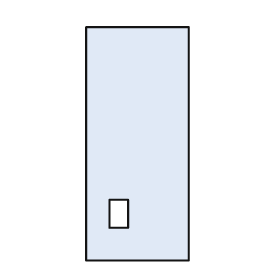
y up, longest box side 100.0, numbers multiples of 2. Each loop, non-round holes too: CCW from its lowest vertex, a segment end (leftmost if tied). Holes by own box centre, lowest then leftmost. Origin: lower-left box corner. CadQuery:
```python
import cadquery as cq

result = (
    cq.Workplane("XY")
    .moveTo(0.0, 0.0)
    .lineTo(44.0, 0.0)
    .lineTo(44.0, 100.0)
    .lineTo(0.0, 100.0)
    .close()
    .moveTo(10.0, 14.0)
    .lineTo(18.0, 14.0)
    .lineTo(18.0, 26.0)
    .lineTo(10.0, 26.0)
    .close()
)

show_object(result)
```